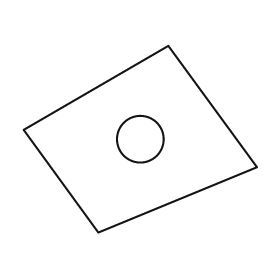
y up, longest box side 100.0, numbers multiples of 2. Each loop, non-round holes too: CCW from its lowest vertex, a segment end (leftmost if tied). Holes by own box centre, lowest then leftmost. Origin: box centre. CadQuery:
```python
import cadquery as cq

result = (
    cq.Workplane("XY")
    .moveTo(-18.0, -40.0)
    .lineTo(50.0, -12.0)
    .lineTo(12.0, 40.0)
    .lineTo(-50.0, 4.0)
    .close()
    .moveTo(0.0, 0.0)
    .circle(10.0)
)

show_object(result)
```